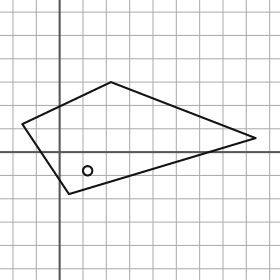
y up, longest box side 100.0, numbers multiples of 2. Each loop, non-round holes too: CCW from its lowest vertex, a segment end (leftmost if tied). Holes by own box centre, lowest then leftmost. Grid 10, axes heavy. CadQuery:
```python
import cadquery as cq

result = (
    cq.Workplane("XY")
    .moveTo(4.0, -18.0)
    .lineTo(84.0, 6.0)
    .lineTo(22.0, 30.0)
    .lineTo(-16.0, 12.0)
    .close()
    .moveTo(12.0, -8.0)
    .circle(2.0)
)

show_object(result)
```